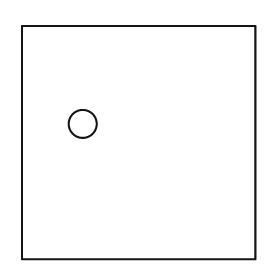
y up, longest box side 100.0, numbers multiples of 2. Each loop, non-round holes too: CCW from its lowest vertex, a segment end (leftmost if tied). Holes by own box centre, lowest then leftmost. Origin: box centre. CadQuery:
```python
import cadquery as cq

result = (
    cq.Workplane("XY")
    .moveTo(-50.0, -50.0)
    .lineTo(50.0, -50.0)
    .lineTo(50.0, 50.0)
    .lineTo(-50.0, 50.0)
    .close()
    .moveTo(-24.0, 8.0)
    .circle(6.0)
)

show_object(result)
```